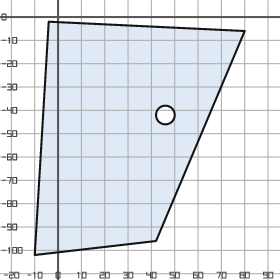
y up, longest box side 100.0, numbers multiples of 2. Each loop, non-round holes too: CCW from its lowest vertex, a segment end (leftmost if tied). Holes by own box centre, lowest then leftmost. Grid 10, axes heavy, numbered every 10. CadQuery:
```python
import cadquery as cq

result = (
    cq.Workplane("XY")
    .moveTo(-10.0, -102.0)
    .lineTo(42.0, -96.0)
    .lineTo(80.0, -6.0)
    .lineTo(-4.0, -2.0)
    .close()
    .moveTo(46.0, -42.0)
    .circle(4.0)
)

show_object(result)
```